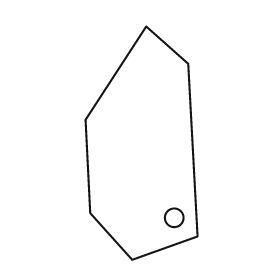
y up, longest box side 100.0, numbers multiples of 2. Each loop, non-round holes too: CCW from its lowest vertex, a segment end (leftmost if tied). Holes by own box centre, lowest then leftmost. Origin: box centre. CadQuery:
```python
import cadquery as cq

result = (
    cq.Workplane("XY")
    .moveTo(-4.0, -50.0)
    .lineTo(24.0, -40.0)
    .lineTo(20.0, 34.0)
    .lineTo(2.0, 50.0)
    .lineTo(-24.0, 10.0)
    .lineTo(-22.0, -30.0)
    .close()
    .moveTo(14.0, -32.0)
    .circle(4.0)
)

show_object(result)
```